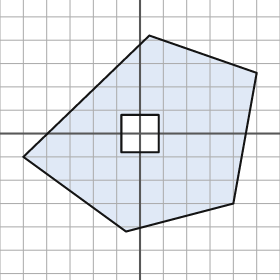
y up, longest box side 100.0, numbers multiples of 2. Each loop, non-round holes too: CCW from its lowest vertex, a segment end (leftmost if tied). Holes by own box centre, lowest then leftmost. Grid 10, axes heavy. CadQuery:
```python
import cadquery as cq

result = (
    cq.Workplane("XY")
    .moveTo(-6.0, -42.0)
    .lineTo(40.0, -30.0)
    .lineTo(50.0, 26.0)
    .lineTo(4.0, 42.0)
    .lineTo(-50.0, -10.0)
    .close()
    .moveTo(-8.0, -8.0)
    .lineTo(8.0, -8.0)
    .lineTo(8.0, 8.0)
    .lineTo(-8.0, 8.0)
    .close()
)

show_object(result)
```